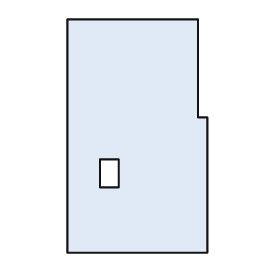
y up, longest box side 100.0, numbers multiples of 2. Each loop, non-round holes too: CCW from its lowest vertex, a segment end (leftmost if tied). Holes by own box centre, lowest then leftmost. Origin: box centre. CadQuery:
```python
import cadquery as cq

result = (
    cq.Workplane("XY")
    .moveTo(-30.0, -50.0)
    .lineTo(30.0, -50.0)
    .lineTo(30.0, 8.0)
    .lineTo(26.0, 8.0)
    .lineTo(26.0, 50.0)
    .lineTo(-30.0, 50.0)
    .close()
    .moveTo(-16.0, -22.0)
    .lineTo(-8.0, -22.0)
    .lineTo(-8.0, -10.0)
    .lineTo(-16.0, -10.0)
    .close()
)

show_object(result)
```